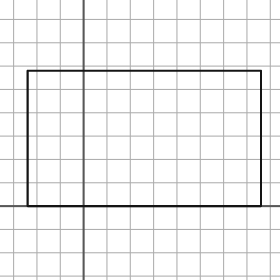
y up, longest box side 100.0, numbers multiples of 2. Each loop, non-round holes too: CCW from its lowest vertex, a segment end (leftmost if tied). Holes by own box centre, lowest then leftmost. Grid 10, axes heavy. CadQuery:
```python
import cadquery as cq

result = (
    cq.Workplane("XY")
    .moveTo(-24.0, 0.0)
    .lineTo(76.0, 0.0)
    .lineTo(76.0, 58.0)
    .lineTo(-24.0, 58.0)
    .close()
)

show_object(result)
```